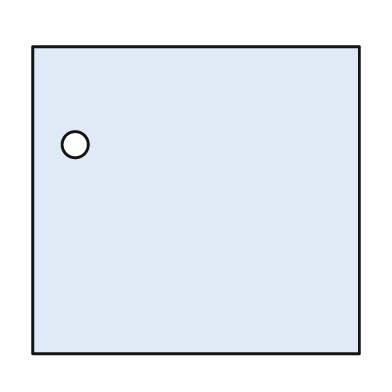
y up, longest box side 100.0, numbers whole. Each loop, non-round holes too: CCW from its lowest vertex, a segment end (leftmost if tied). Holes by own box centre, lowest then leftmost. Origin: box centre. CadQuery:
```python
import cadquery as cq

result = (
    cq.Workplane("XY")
    .moveTo(-50.0, -47.0)
    .lineTo(50.0, -47.0)
    .lineTo(50.0, 47.0)
    .lineTo(-50.0, 47.0)
    .close()
    .moveTo(-37.0, 17.0)
    .circle(4.0)
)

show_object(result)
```